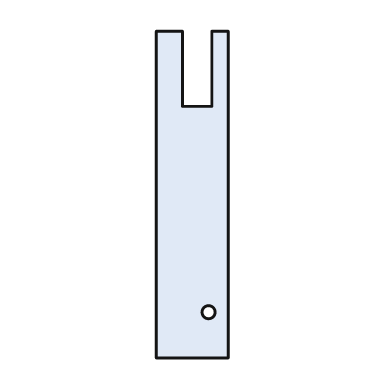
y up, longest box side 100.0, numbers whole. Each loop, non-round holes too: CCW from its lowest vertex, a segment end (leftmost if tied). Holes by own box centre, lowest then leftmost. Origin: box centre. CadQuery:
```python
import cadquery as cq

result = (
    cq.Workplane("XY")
    .moveTo(-11.0, -50.0)
    .lineTo(11.0, -50.0)
    .lineTo(11.0, 50.0)
    .lineTo(6.0, 50.0)
    .lineTo(6.0, 27.0)
    .lineTo(-3.0, 27.0)
    .lineTo(-3.0, 50.0)
    .lineTo(-11.0, 50.0)
    .close()
    .moveTo(5.0, -36.0)
    .circle(2.0)
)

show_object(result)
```